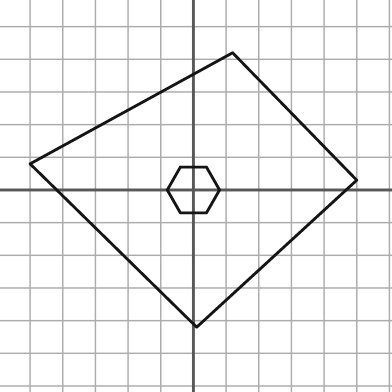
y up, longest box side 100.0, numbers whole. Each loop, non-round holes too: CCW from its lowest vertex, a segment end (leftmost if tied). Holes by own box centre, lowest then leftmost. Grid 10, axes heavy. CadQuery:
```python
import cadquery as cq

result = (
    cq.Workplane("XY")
    .moveTo(1.0, -42.0)
    .lineTo(50.0, 3.0)
    .lineTo(12.0, 42.0)
    .lineTo(-50.0, 8.0)
    .close()
    .moveTo(-4.0, -7.0)
    .lineTo(4.0, -7.0)
    .lineTo(8.0, 0.0)
    .lineTo(4.0, 7.0)
    .lineTo(-4.0, 7.0)
    .lineTo(-8.0, 0.0)
    .close()
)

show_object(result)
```